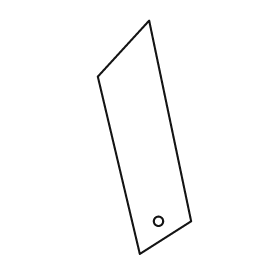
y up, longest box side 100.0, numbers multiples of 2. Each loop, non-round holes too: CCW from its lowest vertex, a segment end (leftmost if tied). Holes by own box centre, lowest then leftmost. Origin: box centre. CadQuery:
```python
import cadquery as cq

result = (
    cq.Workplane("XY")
    .moveTo(-2.0, -50.0)
    .lineTo(20.0, -36.0)
    .lineTo(2.0, 50.0)
    .lineTo(-20.0, 26.0)
    .close()
    .moveTo(6.0, -36.0)
    .circle(2.0)
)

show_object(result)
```